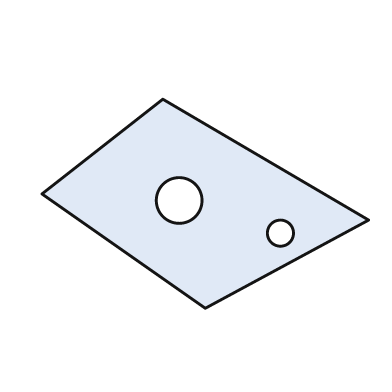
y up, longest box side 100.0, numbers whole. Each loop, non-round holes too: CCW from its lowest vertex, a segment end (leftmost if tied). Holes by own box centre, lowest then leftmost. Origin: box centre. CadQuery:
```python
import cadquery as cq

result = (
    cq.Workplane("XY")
    .moveTo(0.0, -32.0)
    .lineTo(50.0, -5.0)
    .lineTo(-13.0, 32.0)
    .lineTo(-50.0, 3.0)
    .close()
    .moveTo(23.0, -9.0)
    .circle(4.0)
    .moveTo(-8.0, 1.0)
    .circle(7.0)
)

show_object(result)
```